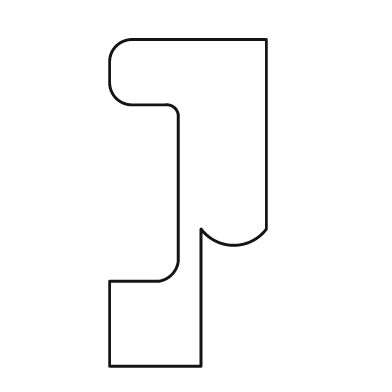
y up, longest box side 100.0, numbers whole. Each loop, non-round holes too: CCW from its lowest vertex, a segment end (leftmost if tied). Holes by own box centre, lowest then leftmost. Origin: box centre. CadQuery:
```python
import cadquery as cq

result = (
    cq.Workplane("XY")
    .moveTo(-24.0, -50.0)
    .lineTo(4.0, -50.0)
    .lineTo(4.0, -8.0)
    .threePointArc((14.0, -13.0), (24.0, -8.0))
    .lineTo(24.0, 50.0)
    .lineTo(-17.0, 50.0)
    .threePointArc((-22.0, 48.0), (-24.0, 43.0))
    .lineTo(-24.0, 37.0)
    .threePointArc((-22.0, 32.0), (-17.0, 30.0))
    .lineTo(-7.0, 30.0)
    .threePointArc((-4.0, 29.0), (-3.0, 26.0))
    .lineTo(-3.0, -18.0)
    .threePointArc((-5.0, -22.0), (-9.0, -24.0))
    .lineTo(-24.0, -24.0)
    .close()
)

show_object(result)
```